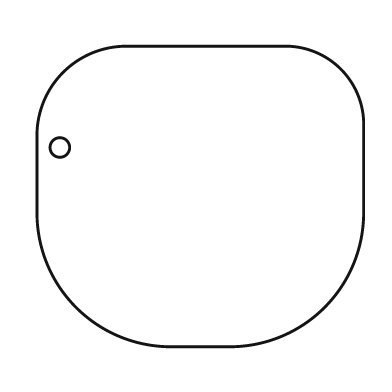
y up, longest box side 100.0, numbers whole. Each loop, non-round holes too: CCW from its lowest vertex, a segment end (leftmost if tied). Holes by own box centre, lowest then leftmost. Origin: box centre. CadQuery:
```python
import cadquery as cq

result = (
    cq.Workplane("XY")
    .moveTo(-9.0, -46.0)
    .lineTo(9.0, -46.0)
    .threePointArc((38.0, -34.0), (50.0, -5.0))
    .lineTo(50.0, 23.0)
    .threePointArc((43.0, 39.0), (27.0, 46.0))
    .lineTo(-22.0, 46.0)
    .threePointArc((-42.0, 38.0), (-50.0, 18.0))
    .lineTo(-50.0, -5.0)
    .threePointArc((-38.0, -34.0), (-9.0, -46.0))
    .close()
    .moveTo(-43.0, 15.0)
    .circle(3.0)
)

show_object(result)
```